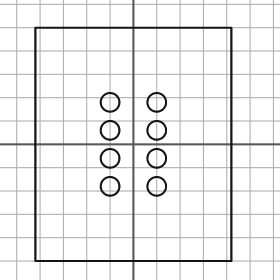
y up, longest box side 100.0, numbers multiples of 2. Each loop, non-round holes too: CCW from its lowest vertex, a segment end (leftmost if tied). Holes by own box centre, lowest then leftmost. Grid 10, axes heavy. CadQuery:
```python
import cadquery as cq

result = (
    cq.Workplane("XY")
    .moveTo(-42.0, -50.0)
    .lineTo(42.0, -50.0)
    .lineTo(42.0, 50.0)
    .lineTo(-42.0, 50.0)
    .close()
    .moveTo(-10.0, -18.0)
    .circle(4.0)
    .moveTo(10.0, -18.0)
    .circle(4.0)
    .moveTo(-10.0, -6.0)
    .circle(4.0)
    .moveTo(10.0, -6.0)
    .circle(4.0)
    .moveTo(-10.0, 6.0)
    .circle(4.0)
    .moveTo(10.0, 6.0)
    .circle(4.0)
    .moveTo(-10.0, 18.0)
    .circle(4.0)
    .moveTo(10.0, 18.0)
    .circle(4.0)
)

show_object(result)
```